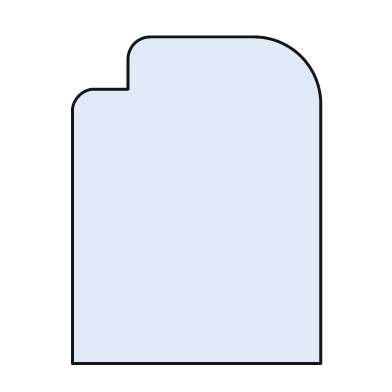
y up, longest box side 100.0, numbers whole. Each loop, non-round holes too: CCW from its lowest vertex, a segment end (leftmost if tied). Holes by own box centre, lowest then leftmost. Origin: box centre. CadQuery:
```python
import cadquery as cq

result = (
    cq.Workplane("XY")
    .moveTo(-38.0, -50.0)
    .lineTo(38.0, -50.0)
    .lineTo(38.0, 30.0)
    .threePointArc((32.0, 44.0), (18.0, 50.0))
    .lineTo(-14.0, 50.0)
    .threePointArc((-19.0, 48.0), (-21.0, 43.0))
    .lineTo(-21.0, 34.0)
    .lineTo(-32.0, 34.0)
    .threePointArc((-36.0, 32.0), (-38.0, 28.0))
    .close()
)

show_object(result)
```